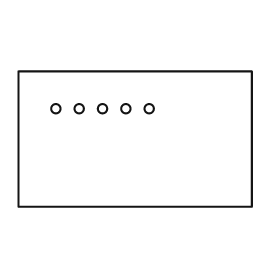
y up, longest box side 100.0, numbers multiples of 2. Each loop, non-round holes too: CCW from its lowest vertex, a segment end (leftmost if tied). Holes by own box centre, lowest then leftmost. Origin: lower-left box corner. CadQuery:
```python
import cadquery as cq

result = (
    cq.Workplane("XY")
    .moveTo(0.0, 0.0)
    .lineTo(100.0, 0.0)
    .lineTo(100.0, 58.0)
    .lineTo(0.0, 58.0)
    .close()
    .moveTo(16.0, 42.0)
    .circle(2.0)
    .moveTo(26.0, 42.0)
    .circle(2.0)
    .moveTo(36.0, 42.0)
    .circle(2.0)
    .moveTo(46.0, 42.0)
    .circle(2.0)
    .moveTo(56.0, 42.0)
    .circle(2.0)
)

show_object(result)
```